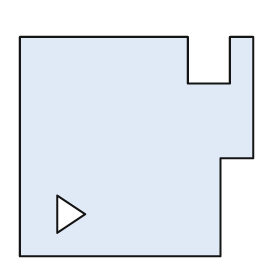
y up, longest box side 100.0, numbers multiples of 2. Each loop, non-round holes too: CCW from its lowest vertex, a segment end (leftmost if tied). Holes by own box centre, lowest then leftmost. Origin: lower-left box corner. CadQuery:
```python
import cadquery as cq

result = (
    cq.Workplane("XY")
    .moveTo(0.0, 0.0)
    .lineTo(86.0, 0.0)
    .lineTo(86.0, 42.0)
    .lineTo(100.0, 42.0)
    .lineTo(100.0, 94.0)
    .lineTo(90.0, 94.0)
    .lineTo(90.0, 74.0)
    .lineTo(72.0, 74.0)
    .lineTo(72.0, 94.0)
    .lineTo(0.0, 94.0)
    .close()
    .moveTo(16.0, 10.0)
    .lineTo(28.0, 18.0)
    .lineTo(16.0, 26.0)
    .close()
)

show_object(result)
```